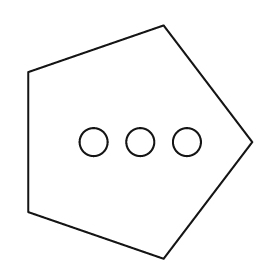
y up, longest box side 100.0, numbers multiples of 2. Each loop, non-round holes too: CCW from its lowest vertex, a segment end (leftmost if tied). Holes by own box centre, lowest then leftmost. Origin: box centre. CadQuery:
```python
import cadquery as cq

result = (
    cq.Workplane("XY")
    .moveTo(10.0, -50.0)
    .lineTo(48.0, 0.0)
    .lineTo(10.0, 50.0)
    .lineTo(-48.0, 30.0)
    .lineTo(-48.0, -30.0)
    .close()
    .moveTo(-20.0, 0.0)
    .circle(6.0)
    .moveTo(0.0, 0.0)
    .circle(6.0)
    .moveTo(20.0, 0.0)
    .circle(6.0)
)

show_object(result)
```